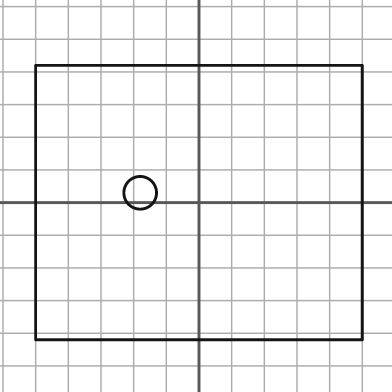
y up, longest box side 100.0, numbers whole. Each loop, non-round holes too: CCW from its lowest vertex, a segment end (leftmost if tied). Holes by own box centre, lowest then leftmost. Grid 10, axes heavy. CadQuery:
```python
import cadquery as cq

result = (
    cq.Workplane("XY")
    .moveTo(-50.0, -42.0)
    .lineTo(50.0, -42.0)
    .lineTo(50.0, 42.0)
    .lineTo(-50.0, 42.0)
    .close()
    .moveTo(-18.0, 3.0)
    .circle(5.0)
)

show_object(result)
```